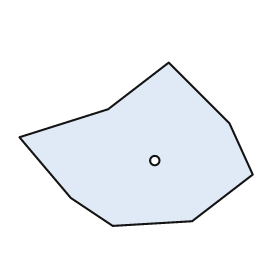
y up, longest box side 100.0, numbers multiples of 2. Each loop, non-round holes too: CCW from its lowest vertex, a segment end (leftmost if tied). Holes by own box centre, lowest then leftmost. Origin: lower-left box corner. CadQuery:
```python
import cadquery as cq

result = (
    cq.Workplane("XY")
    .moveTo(40.0, 0.0)
    .lineTo(74.0, 2.0)
    .lineTo(100.0, 22.0)
    .lineTo(90.0, 44.0)
    .lineTo(64.0, 70.0)
    .lineTo(38.0, 50.0)
    .lineTo(0.0, 38.0)
    .lineTo(22.0, 12.0)
    .close()
    .moveTo(58.0, 28.0)
    .circle(2.0)
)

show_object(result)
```